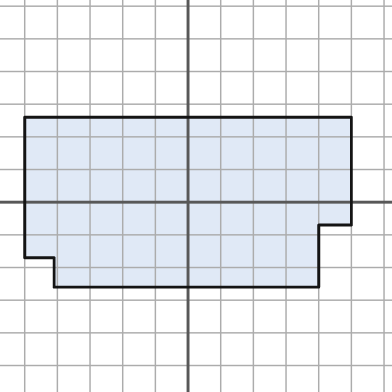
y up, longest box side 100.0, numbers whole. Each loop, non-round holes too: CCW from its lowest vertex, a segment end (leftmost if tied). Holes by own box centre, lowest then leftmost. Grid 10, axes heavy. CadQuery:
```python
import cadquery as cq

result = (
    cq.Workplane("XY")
    .moveTo(-41.0, -26.0)
    .lineTo(40.0, -26.0)
    .lineTo(40.0, -7.0)
    .lineTo(50.0, -7.0)
    .lineTo(50.0, 26.0)
    .lineTo(-50.0, 26.0)
    .lineTo(-50.0, -17.0)
    .lineTo(-41.0, -17.0)
    .close()
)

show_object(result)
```